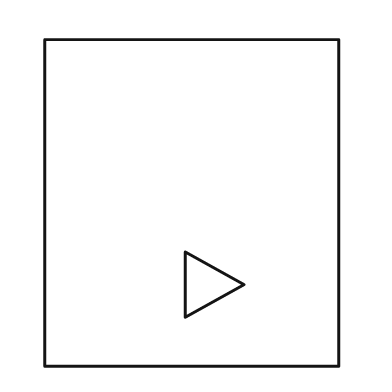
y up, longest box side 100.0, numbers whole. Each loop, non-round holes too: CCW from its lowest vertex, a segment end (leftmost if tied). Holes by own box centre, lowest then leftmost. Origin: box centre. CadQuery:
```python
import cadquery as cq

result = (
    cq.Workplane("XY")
    .moveTo(-45.0, -50.0)
    .lineTo(45.0, -50.0)
    .lineTo(45.0, 50.0)
    .lineTo(-45.0, 50.0)
    .close()
    .moveTo(-2.0, -35.0)
    .lineTo(16.0, -25.0)
    .lineTo(-2.0, -15.0)
    .close()
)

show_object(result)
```